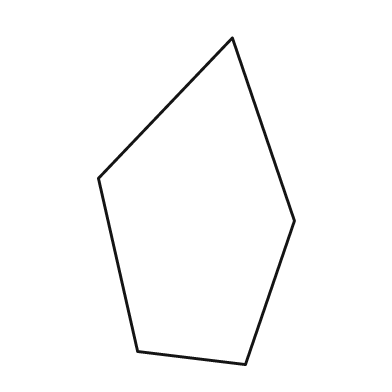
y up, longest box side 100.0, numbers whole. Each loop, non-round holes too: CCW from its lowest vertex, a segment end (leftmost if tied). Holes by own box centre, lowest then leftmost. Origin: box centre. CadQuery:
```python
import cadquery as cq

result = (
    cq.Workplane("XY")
    .moveTo(15.0, -50.0)
    .lineTo(30.0, -6.0)
    .lineTo(11.0, 50.0)
    .lineTo(-30.0, 7.0)
    .lineTo(-18.0, -46.0)
    .close()
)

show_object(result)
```